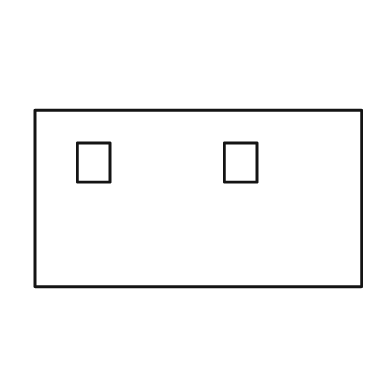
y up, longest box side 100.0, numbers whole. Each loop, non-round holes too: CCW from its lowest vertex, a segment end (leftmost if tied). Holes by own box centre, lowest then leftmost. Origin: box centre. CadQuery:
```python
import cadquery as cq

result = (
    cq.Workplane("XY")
    .moveTo(-50.0, -27.0)
    .lineTo(50.0, -27.0)
    .lineTo(50.0, 27.0)
    .lineTo(-50.0, 27.0)
    .close()
    .moveTo(-37.0, 5.0)
    .lineTo(-27.0, 5.0)
    .lineTo(-27.0, 17.0)
    .lineTo(-37.0, 17.0)
    .close()
    .moveTo(8.0, 5.0)
    .lineTo(18.0, 5.0)
    .lineTo(18.0, 17.0)
    .lineTo(8.0, 17.0)
    .close()
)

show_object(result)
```